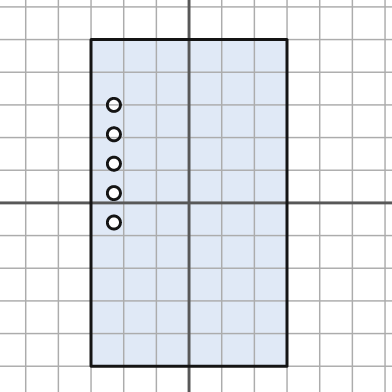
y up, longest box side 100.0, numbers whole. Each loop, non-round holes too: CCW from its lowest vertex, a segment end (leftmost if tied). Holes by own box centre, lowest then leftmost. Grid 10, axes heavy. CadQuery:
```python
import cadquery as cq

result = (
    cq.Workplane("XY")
    .moveTo(-30.0, -50.0)
    .lineTo(30.0, -50.0)
    .lineTo(30.0, 50.0)
    .lineTo(-30.0, 50.0)
    .close()
    .moveTo(-23.0, -6.0)
    .circle(2.0)
    .moveTo(-23.0, 3.0)
    .circle(2.0)
    .moveTo(-23.0, 12.0)
    .circle(2.0)
    .moveTo(-23.0, 21.0)
    .circle(2.0)
    .moveTo(-23.0, 30.0)
    .circle(2.0)
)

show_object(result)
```